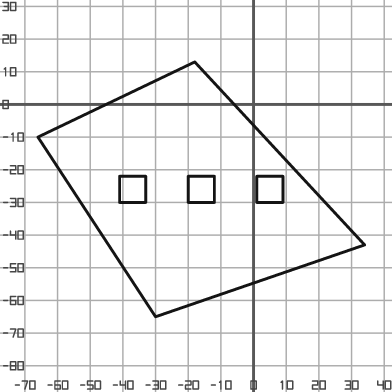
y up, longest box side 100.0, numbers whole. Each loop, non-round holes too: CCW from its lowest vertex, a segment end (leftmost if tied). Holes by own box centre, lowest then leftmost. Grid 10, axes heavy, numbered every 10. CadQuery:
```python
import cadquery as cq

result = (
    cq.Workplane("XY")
    .moveTo(-30.0, -65.0)
    .lineTo(34.0, -43.0)
    .lineTo(-18.0, 13.0)
    .lineTo(-66.0, -10.0)
    .close()
    .moveTo(-41.0, -30.0)
    .lineTo(-33.0, -30.0)
    .lineTo(-33.0, -22.0)
    .lineTo(-41.0, -22.0)
    .close()
    .moveTo(-20.0, -30.0)
    .lineTo(-12.0, -30.0)
    .lineTo(-12.0, -22.0)
    .lineTo(-20.0, -22.0)
    .close()
    .moveTo(1.0, -30.0)
    .lineTo(9.0, -30.0)
    .lineTo(9.0, -22.0)
    .lineTo(1.0, -22.0)
    .close()
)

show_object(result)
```